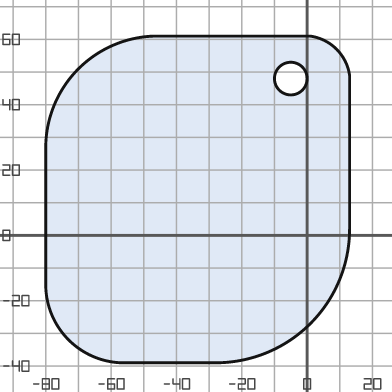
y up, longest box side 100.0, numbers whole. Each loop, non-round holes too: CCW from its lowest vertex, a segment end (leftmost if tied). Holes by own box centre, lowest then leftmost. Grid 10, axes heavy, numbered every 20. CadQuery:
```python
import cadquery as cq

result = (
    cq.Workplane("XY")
    .moveTo(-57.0, -39.0)
    .lineTo(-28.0, -39.0)
    .threePointArc((1.0, -27.0), (13.0, 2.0))
    .lineTo(13.0, 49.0)
    .threePointArc((9.0, 57.0), (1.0, 61.0))
    .lineTo(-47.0, 61.0)
    .threePointArc((-70.0, 51.0), (-80.0, 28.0))
    .lineTo(-80.0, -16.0)
    .threePointArc((-73.0, -32.0), (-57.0, -39.0))
    .close()
    .moveTo(-5.0, 48.0)
    .circle(5.0)
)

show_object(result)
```